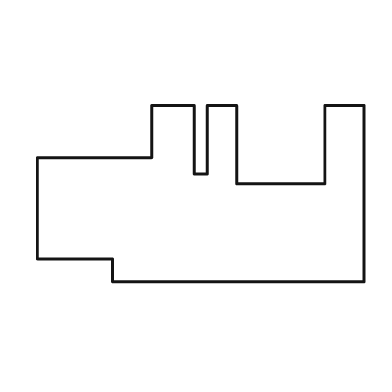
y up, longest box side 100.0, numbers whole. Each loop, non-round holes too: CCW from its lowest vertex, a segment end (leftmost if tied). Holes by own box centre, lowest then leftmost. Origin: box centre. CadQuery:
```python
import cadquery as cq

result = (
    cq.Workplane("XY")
    .moveTo(-27.0, -27.0)
    .lineTo(50.0, -27.0)
    .lineTo(50.0, 27.0)
    .lineTo(38.0, 27.0)
    .lineTo(38.0, 3.0)
    .lineTo(11.0, 3.0)
    .lineTo(11.0, 27.0)
    .lineTo(2.0, 27.0)
    .lineTo(2.0, 6.0)
    .lineTo(-2.0, 6.0)
    .lineTo(-2.0, 27.0)
    .lineTo(-15.0, 27.0)
    .lineTo(-15.0, 11.0)
    .lineTo(-50.0, 11.0)
    .lineTo(-50.0, -20.0)
    .lineTo(-27.0, -20.0)
    .close()
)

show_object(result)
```